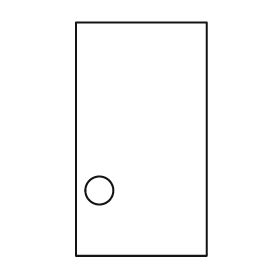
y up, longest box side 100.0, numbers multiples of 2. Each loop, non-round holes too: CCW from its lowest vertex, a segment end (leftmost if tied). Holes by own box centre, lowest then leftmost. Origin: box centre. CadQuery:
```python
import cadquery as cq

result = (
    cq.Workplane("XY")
    .moveTo(-28.0, -50.0)
    .lineTo(28.0, -50.0)
    .lineTo(28.0, 50.0)
    .lineTo(-28.0, 50.0)
    .close()
    .moveTo(-18.0, -22.0)
    .circle(6.0)
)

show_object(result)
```